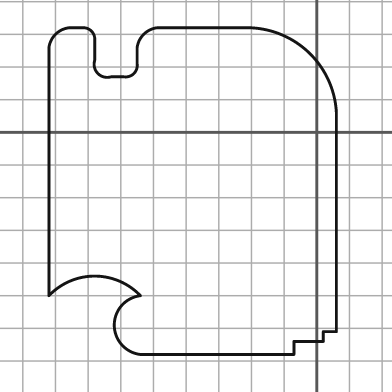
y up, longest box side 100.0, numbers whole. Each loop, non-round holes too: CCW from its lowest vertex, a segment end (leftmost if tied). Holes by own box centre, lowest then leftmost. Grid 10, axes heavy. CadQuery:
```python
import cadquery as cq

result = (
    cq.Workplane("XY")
    .moveTo(-54.0, -68.0)
    .lineTo(-7.0, -68.0)
    .lineTo(-7.0, -64.0)
    .lineTo(2.0, -64.0)
    .lineTo(2.0, -61.0)
    .lineTo(6.0, -61.0)
    .lineTo(6.0, 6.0)
    .threePointArc((-2.0, 24.0), (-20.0, 32.0))
    .lineTo(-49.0, 32.0)
    .threePointArc((-53.0, 30.0), (-55.0, 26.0))
    .lineTo(-55.0, 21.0)
    .threePointArc((-56.0, 18.0), (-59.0, 17.0))
    .lineTo(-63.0, 17.0)
    .threePointArc((-67.0, 18.0), (-68.0, 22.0))
    .lineTo(-68.0, 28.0)
    .threePointArc((-69.0, 31.0), (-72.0, 32.0))
    .lineTo(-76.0, 32.0)
    .threePointArc((-80.0, 30.0), (-82.0, 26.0))
    .lineTo(-82.0, -50.0)
    .threePointArc((-68.0, -44.0), (-54.0, -50.0))
    .threePointArc((-62.0, -59.0), (-54.0, -68.0))
    .close()
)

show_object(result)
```